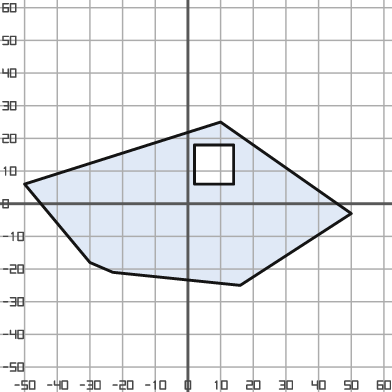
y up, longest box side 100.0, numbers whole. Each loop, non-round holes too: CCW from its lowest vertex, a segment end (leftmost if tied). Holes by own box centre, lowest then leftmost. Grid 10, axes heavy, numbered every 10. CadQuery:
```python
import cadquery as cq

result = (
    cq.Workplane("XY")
    .moveTo(16.0, -25.0)
    .lineTo(50.0, -3.0)
    .lineTo(10.0, 25.0)
    .lineTo(-50.0, 6.0)
    .lineTo(-30.0, -18.0)
    .lineTo(-23.0, -21.0)
    .close()
    .moveTo(2.0, 6.0)
    .lineTo(14.0, 6.0)
    .lineTo(14.0, 18.0)
    .lineTo(2.0, 18.0)
    .close()
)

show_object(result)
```